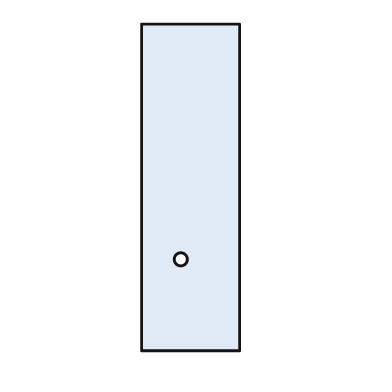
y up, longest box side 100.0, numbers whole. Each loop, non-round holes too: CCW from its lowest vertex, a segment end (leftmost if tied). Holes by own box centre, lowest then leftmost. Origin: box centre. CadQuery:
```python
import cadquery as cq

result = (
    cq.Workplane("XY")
    .moveTo(-15.0, -50.0)
    .lineTo(15.0, -50.0)
    .lineTo(15.0, 50.0)
    .lineTo(-15.0, 50.0)
    .close()
    .moveTo(-3.0, -22.0)
    .circle(2.0)
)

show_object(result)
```